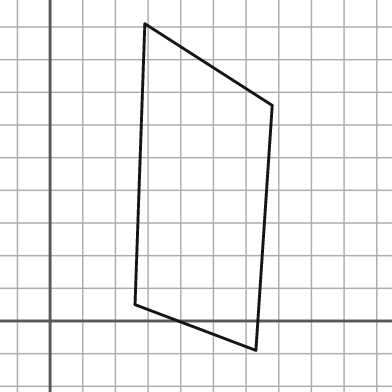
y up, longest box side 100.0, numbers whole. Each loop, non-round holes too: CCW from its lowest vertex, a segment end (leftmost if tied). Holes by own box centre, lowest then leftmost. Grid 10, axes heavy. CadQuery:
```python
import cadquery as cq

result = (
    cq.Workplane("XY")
    .moveTo(63.0, -9.0)
    .lineTo(68.0, 66.0)
    .lineTo(29.0, 91.0)
    .lineTo(26.0, 5.0)
    .close()
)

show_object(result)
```